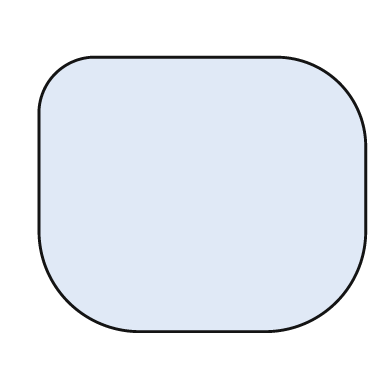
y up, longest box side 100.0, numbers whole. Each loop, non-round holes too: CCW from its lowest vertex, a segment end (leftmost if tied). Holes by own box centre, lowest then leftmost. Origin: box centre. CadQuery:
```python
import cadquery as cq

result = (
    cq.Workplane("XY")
    .moveTo(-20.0, -42.0)
    .lineTo(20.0, -42.0)
    .threePointArc((41.0, -33.0), (50.0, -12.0))
    .lineTo(50.0, 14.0)
    .threePointArc((42.0, 34.0), (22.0, 42.0))
    .lineTo(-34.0, 42.0)
    .threePointArc((-45.0, 37.0), (-50.0, 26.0))
    .lineTo(-50.0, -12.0)
    .threePointArc((-41.0, -33.0), (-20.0, -42.0))
    .close()
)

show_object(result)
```